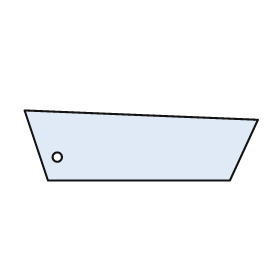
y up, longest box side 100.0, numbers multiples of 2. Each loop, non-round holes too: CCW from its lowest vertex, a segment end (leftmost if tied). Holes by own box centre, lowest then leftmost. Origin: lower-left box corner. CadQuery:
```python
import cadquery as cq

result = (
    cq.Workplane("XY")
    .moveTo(10.0, 0.0)
    .lineTo(88.0, 0.0)
    .lineTo(100.0, 26.0)
    .lineTo(0.0, 30.0)
    .close()
    .moveTo(14.0, 10.0)
    .circle(2.0)
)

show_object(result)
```